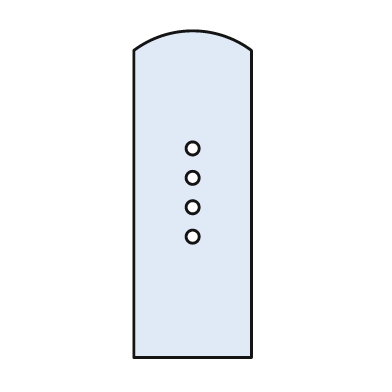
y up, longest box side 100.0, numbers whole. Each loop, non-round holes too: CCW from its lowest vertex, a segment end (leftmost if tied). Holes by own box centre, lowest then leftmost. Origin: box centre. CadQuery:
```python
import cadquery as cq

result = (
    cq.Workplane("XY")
    .moveTo(-18.0, -50.0)
    .lineTo(18.0, -50.0)
    .lineTo(18.0, 44.0)
    .threePointArc((0.0, 50.0), (-18.0, 44.0))
    .close()
    .moveTo(0.0, -13.0)
    .circle(2.0)
    .moveTo(0.0, -4.0)
    .circle(2.0)
    .moveTo(0.0, 5.0)
    .circle(2.0)
    .moveTo(0.0, 14.0)
    .circle(2.0)
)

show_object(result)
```